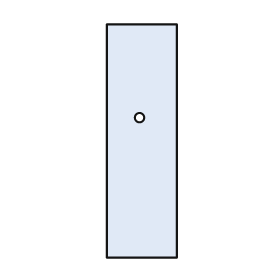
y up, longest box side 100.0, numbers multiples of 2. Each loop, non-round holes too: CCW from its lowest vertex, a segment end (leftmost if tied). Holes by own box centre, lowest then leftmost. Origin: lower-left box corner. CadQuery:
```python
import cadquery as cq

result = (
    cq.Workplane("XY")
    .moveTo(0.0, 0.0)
    .lineTo(30.0, 0.0)
    .lineTo(30.0, 100.0)
    .lineTo(0.0, 100.0)
    .close()
    .moveTo(14.0, 60.0)
    .circle(2.0)
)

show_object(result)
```